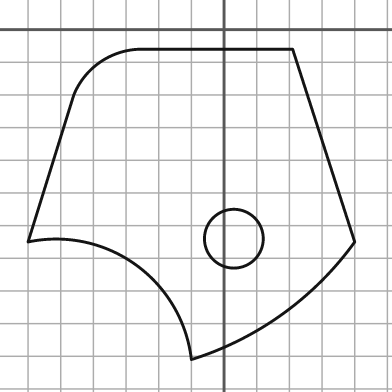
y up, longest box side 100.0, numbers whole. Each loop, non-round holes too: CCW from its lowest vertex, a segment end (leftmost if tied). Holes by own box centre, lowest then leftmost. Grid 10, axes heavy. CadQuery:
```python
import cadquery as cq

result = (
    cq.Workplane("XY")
    .moveTo(-10.0, -101.0)
    .threePointArc((18.0, -87.0), (40.0, -65.0))
    .lineTo(21.0, -6.0)
    .lineTo(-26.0, -6.0)
    .threePointArc((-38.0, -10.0), (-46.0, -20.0))
    .lineTo(-60.0, -65.0)
    .threePointArc((-27.0, -72.0), (-10.0, -101.0))
    .close()
    .moveTo(3.0, -64.0)
    .circle(9.0)
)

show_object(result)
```